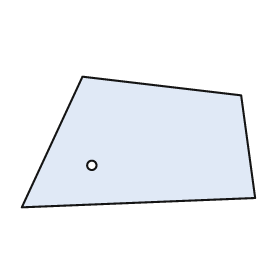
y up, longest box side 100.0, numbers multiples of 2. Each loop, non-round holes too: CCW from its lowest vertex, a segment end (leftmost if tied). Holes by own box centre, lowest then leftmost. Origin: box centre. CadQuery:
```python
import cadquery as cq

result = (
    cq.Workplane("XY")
    .moveTo(-50.0, -28.0)
    .lineTo(50.0, -24.0)
    .lineTo(44.0, 20.0)
    .lineTo(-24.0, 28.0)
    .close()
    .moveTo(-20.0, -10.0)
    .circle(2.0)
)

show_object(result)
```